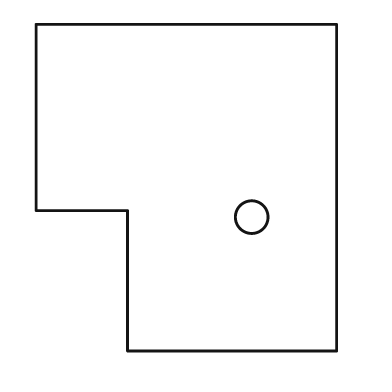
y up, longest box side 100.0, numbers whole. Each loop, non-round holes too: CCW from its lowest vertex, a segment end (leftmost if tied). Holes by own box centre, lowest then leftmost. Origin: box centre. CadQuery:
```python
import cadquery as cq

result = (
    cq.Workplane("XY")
    .moveTo(-18.0, -50.0)
    .lineTo(46.0, -50.0)
    .lineTo(46.0, 50.0)
    .lineTo(-46.0, 50.0)
    .lineTo(-46.0, -7.0)
    .lineTo(-18.0, -7.0)
    .close()
    .moveTo(20.0, -9.0)
    .circle(5.0)
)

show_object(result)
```